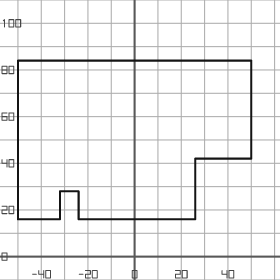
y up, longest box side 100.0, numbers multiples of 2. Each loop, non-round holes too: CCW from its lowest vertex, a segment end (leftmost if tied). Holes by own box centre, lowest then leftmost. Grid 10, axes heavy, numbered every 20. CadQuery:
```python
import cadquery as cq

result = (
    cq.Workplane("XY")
    .moveTo(-50.0, 16.0)
    .lineTo(-32.0, 16.0)
    .lineTo(-32.0, 28.0)
    .lineTo(-24.0, 28.0)
    .lineTo(-24.0, 16.0)
    .lineTo(26.0, 16.0)
    .lineTo(26.0, 42.0)
    .lineTo(50.0, 42.0)
    .lineTo(50.0, 84.0)
    .lineTo(-50.0, 84.0)
    .close()
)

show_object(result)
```